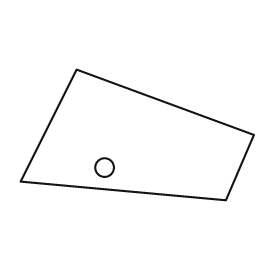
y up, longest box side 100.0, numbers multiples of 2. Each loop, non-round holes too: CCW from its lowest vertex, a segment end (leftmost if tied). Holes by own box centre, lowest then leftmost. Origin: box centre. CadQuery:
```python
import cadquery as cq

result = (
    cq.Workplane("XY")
    .moveTo(38.0, -28.0)
    .lineTo(50.0, 0.0)
    .lineTo(-26.0, 28.0)
    .lineTo(-50.0, -20.0)
    .close()
    .moveTo(-14.0, -14.0)
    .circle(4.0)
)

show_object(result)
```